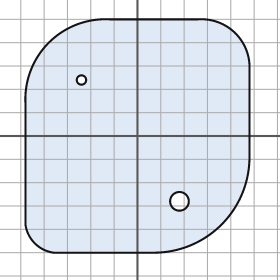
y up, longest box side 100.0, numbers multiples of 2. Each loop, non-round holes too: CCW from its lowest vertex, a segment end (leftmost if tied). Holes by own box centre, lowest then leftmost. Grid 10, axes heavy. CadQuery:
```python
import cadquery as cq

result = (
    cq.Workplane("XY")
    .moveTo(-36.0, -50.0)
    .lineTo(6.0, -50.0)
    .threePointArc((36.0, -38.0), (48.0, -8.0))
    .lineTo(48.0, 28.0)
    .threePointArc((42.0, 44.0), (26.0, 50.0))
    .lineTo(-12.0, 50.0)
    .threePointArc((-38.0, 40.0), (-48.0, 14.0))
    .lineTo(-48.0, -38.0)
    .threePointArc((-44.0, -46.0), (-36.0, -50.0))
    .close()
    .moveTo(18.0, -28.0)
    .circle(4.0)
    .moveTo(-24.0, 24.0)
    .circle(2.0)
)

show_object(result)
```